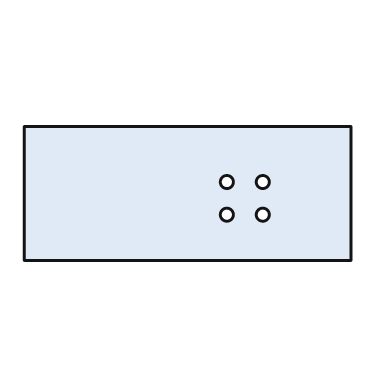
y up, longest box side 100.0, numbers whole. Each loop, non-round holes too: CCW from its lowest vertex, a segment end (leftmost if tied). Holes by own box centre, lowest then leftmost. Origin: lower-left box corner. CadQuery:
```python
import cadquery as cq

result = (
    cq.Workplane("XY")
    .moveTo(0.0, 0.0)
    .lineTo(100.0, 0.0)
    .lineTo(100.0, 41.0)
    .lineTo(0.0, 41.0)
    .close()
    .moveTo(62.0, 14.0)
    .circle(2.0)
    .moveTo(73.0, 14.0)
    .circle(2.0)
    .moveTo(62.0, 24.0)
    .circle(2.0)
    .moveTo(73.0, 24.0)
    .circle(2.0)
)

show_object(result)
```